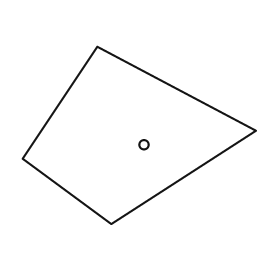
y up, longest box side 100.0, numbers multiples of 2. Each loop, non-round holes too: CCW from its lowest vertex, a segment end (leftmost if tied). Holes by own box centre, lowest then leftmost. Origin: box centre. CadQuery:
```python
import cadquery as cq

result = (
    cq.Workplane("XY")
    .moveTo(-12.0, -38.0)
    .lineTo(50.0, 2.0)
    .lineTo(-18.0, 38.0)
    .lineTo(-50.0, -10.0)
    .close()
    .moveTo(2.0, -4.0)
    .circle(2.0)
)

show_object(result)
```